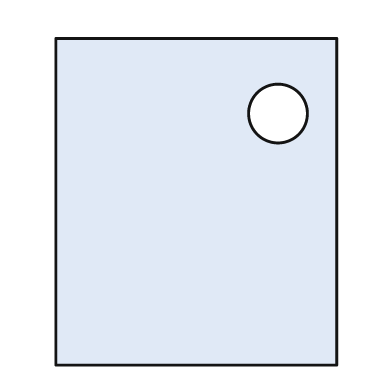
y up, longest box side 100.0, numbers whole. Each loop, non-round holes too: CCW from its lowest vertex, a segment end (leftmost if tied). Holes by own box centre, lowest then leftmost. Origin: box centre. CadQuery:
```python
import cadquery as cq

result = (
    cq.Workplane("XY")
    .moveTo(-43.0, -50.0)
    .lineTo(43.0, -50.0)
    .lineTo(43.0, 50.0)
    .lineTo(-43.0, 50.0)
    .close()
    .moveTo(25.0, 27.0)
    .circle(9.0)
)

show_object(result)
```